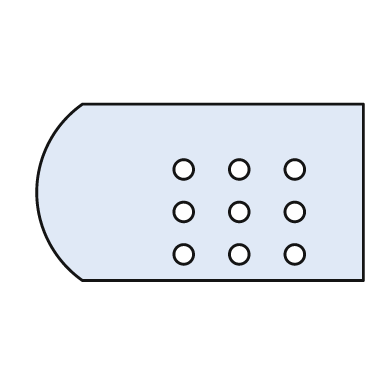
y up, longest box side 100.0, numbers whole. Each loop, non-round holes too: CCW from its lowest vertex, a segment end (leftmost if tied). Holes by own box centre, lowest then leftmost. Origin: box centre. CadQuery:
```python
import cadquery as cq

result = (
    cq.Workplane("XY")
    .moveTo(-36.0, -27.0)
    .lineTo(50.0, -27.0)
    .lineTo(50.0, 27.0)
    .lineTo(-36.0, 27.0)
    .threePointArc((-50.0, 0.0), (-36.0, -27.0))
    .close()
    .moveTo(-5.0, -19.0)
    .circle(3.0)
    .moveTo(12.0, -19.0)
    .circle(3.0)
    .moveTo(29.0, -19.0)
    .circle(3.0)
    .moveTo(-5.0, -6.0)
    .circle(3.0)
    .moveTo(12.0, -6.0)
    .circle(3.0)
    .moveTo(29.0, -6.0)
    .circle(3.0)
    .moveTo(-5.0, 7.0)
    .circle(3.0)
    .moveTo(12.0, 7.0)
    .circle(3.0)
    .moveTo(29.0, 7.0)
    .circle(3.0)
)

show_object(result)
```